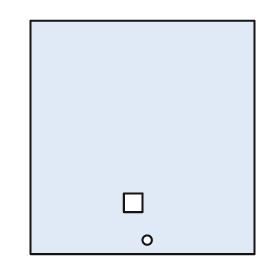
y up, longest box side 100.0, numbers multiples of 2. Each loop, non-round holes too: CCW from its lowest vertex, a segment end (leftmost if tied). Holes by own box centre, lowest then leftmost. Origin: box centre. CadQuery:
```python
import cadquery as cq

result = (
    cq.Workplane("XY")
    .moveTo(-48.0, -50.0)
    .lineTo(48.0, -50.0)
    .lineTo(48.0, 50.0)
    .lineTo(-48.0, 50.0)
    .close()
    .moveTo(2.0, -44.0)
    .circle(2.0)
    .moveTo(-8.0, -32.0)
    .lineTo(0.0, -32.0)
    .lineTo(0.0, -24.0)
    .lineTo(-8.0, -24.0)
    .close()
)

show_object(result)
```